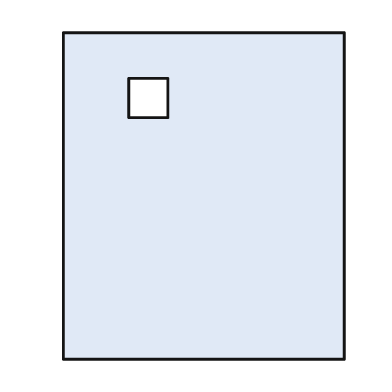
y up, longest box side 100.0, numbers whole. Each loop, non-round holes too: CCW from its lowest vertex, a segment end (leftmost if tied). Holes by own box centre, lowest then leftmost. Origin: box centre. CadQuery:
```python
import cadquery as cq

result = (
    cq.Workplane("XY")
    .moveTo(-43.0, -50.0)
    .lineTo(43.0, -50.0)
    .lineTo(43.0, 50.0)
    .lineTo(-43.0, 50.0)
    .close()
    .moveTo(-23.0, 24.0)
    .lineTo(-11.0, 24.0)
    .lineTo(-11.0, 36.0)
    .lineTo(-23.0, 36.0)
    .close()
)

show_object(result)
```